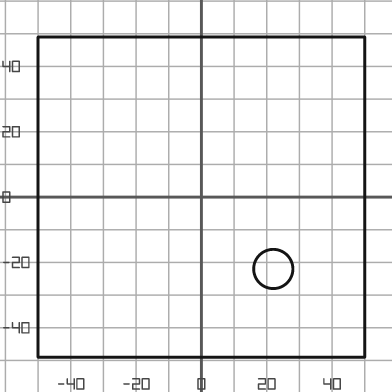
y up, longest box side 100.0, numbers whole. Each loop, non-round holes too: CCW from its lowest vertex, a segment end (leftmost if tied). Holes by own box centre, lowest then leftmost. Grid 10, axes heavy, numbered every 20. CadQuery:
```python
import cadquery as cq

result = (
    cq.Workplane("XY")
    .moveTo(-50.0, -49.0)
    .lineTo(50.0, -49.0)
    .lineTo(50.0, 49.0)
    .lineTo(-50.0, 49.0)
    .close()
    .moveTo(22.0, -22.0)
    .circle(6.0)
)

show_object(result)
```